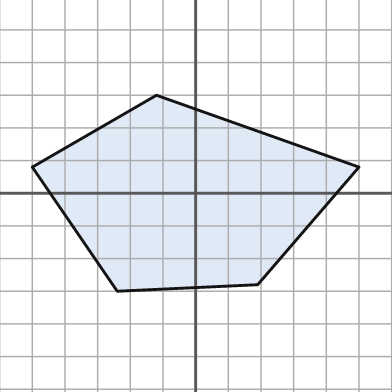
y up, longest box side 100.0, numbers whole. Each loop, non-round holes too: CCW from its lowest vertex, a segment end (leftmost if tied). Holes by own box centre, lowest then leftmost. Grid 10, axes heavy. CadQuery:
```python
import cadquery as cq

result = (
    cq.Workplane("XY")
    .moveTo(-24.0, -30.0)
    .lineTo(19.0, -28.0)
    .lineTo(50.0, 8.0)
    .lineTo(-12.0, 30.0)
    .lineTo(-50.0, 8.0)
    .close()
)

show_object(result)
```